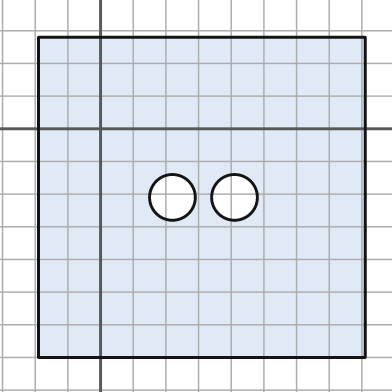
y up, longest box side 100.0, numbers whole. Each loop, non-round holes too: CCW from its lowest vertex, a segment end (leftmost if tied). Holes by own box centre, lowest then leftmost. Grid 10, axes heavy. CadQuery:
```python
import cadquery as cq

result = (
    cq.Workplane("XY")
    .moveTo(-19.0, -70.0)
    .lineTo(81.0, -70.0)
    .lineTo(81.0, 28.0)
    .lineTo(-19.0, 28.0)
    .close()
    .moveTo(22.0, -21.0)
    .circle(7.0)
    .moveTo(41.0, -21.0)
    .circle(7.0)
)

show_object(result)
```